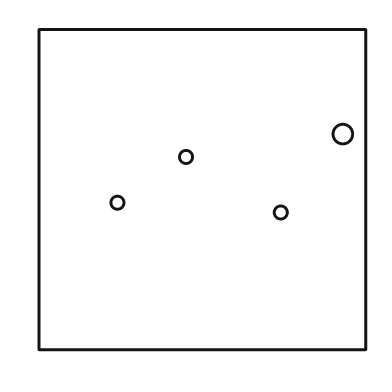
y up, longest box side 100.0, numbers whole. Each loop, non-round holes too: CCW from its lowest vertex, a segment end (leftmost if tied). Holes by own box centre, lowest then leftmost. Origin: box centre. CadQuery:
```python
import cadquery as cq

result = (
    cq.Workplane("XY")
    .moveTo(-50.0, -49.0)
    .lineTo(50.0, -49.0)
    .lineTo(50.0, 49.0)
    .lineTo(-50.0, 49.0)
    .close()
    .moveTo(24.0, -7.0)
    .circle(2.0)
    .moveTo(-26.0, -4.0)
    .circle(2.0)
    .moveTo(-5.0, 10.0)
    .circle(2.0)
    .moveTo(43.0, 17.0)
    .circle(3.0)
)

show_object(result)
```